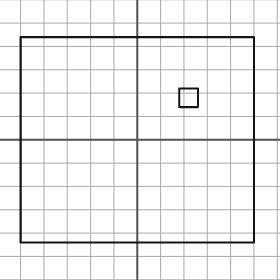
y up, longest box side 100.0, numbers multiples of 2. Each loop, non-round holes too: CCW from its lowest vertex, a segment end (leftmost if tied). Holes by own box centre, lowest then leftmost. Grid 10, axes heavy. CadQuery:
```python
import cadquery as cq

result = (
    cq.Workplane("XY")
    .moveTo(-50.0, -44.0)
    .lineTo(50.0, -44.0)
    .lineTo(50.0, 44.0)
    .lineTo(-50.0, 44.0)
    .close()
    .moveTo(18.0, 14.0)
    .lineTo(26.0, 14.0)
    .lineTo(26.0, 22.0)
    .lineTo(18.0, 22.0)
    .close()
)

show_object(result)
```